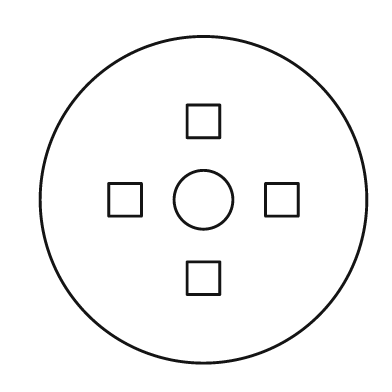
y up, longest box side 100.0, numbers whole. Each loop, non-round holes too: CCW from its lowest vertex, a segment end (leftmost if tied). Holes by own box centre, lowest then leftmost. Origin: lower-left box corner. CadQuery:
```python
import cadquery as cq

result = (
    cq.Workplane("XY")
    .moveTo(50.0, 50.0)
    .circle(50.0)
    .moveTo(45.0, 21.0)
    .lineTo(55.0, 21.0)
    .lineTo(55.0, 31.0)
    .lineTo(45.0, 31.0)
    .close()
    .moveTo(21.0, 45.0)
    .lineTo(31.0, 45.0)
    .lineTo(31.0, 55.0)
    .lineTo(21.0, 55.0)
    .close()
    .moveTo(50.0, 50.0)
    .circle(9.0)
    .moveTo(69.0, 45.0)
    .lineTo(79.0, 45.0)
    .lineTo(79.0, 55.0)
    .lineTo(69.0, 55.0)
    .close()
    .moveTo(45.0, 69.0)
    .lineTo(55.0, 69.0)
    .lineTo(55.0, 79.0)
    .lineTo(45.0, 79.0)
    .close()
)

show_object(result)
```